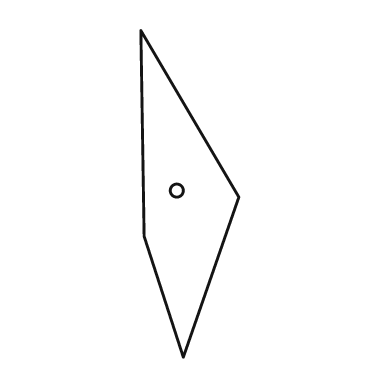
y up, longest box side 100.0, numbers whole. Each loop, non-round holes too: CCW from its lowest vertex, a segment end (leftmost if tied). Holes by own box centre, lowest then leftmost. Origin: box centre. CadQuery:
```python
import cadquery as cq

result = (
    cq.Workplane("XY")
    .moveTo(-2.0, -50.0)
    .lineTo(15.0, -1.0)
    .lineTo(-15.0, 50.0)
    .lineTo(-14.0, -13.0)
    .close()
    .moveTo(-4.0, 1.0)
    .circle(2.0)
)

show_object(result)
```